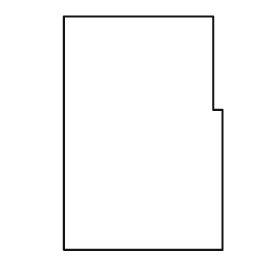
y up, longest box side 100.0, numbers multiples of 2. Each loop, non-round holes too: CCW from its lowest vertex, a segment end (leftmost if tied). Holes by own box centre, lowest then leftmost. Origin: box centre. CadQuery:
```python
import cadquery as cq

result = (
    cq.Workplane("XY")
    .moveTo(-34.0, -50.0)
    .lineTo(34.0, -50.0)
    .lineTo(34.0, 10.0)
    .lineTo(30.0, 10.0)
    .lineTo(30.0, 50.0)
    .lineTo(-34.0, 50.0)
    .close()
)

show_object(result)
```